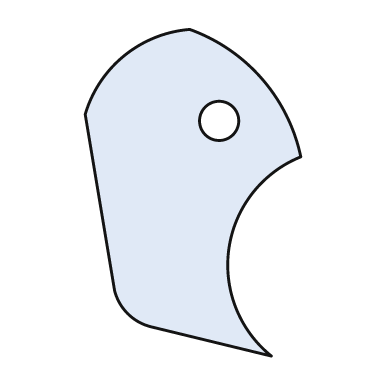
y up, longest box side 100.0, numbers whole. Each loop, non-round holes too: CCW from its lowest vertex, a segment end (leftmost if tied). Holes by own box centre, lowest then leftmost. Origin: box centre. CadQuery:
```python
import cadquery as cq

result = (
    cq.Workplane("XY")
    .moveTo(24.0, -50.0)
    .threePointArc((11.0, -17.0), (33.0, 11.0))
    .threePointArc((21.0, 35.0), (-1.0, 50.0))
    .threePointArc((-21.0, 42.0), (-33.0, 24.0))
    .lineTo(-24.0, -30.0)
    .threePointArc((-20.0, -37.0), (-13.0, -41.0))
    .close()
    .moveTo(8.0, 22.0)
    .circle(6.0)
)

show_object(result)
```